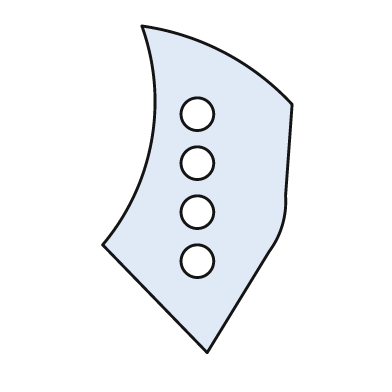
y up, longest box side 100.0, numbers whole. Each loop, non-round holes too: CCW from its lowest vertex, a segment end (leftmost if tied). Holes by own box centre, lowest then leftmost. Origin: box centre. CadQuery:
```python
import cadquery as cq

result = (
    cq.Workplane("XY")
    .moveTo(3.0, -50.0)
    .lineTo(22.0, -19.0)
    .threePointArc((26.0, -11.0), (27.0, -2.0))
    .lineTo(29.0, 26.0)
    .threePointArc((8.0, 42.0), (-17.0, 50.0))
    .threePointArc((-14.0, 15.0), (-29.0, -17.0))
    .close()
    .moveTo(0.0, -22.0)
    .circle(5.0)
    .moveTo(0.0, -7.0)
    .circle(5.0)
    .moveTo(0.0, 8.0)
    .circle(5.0)
    .moveTo(0.0, 23.0)
    .circle(5.0)
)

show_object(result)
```